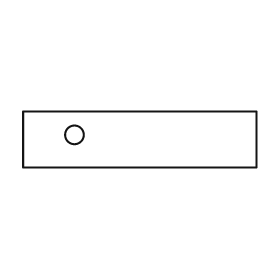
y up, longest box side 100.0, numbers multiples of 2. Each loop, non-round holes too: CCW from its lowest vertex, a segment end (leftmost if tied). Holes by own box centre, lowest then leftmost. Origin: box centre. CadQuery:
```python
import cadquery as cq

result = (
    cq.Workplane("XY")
    .moveTo(-50.0, -12.0)
    .lineTo(50.0, -12.0)
    .lineTo(50.0, 12.0)
    .lineTo(-50.0, 12.0)
    .close()
    .moveTo(-28.0, 2.0)
    .circle(4.0)
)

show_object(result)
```